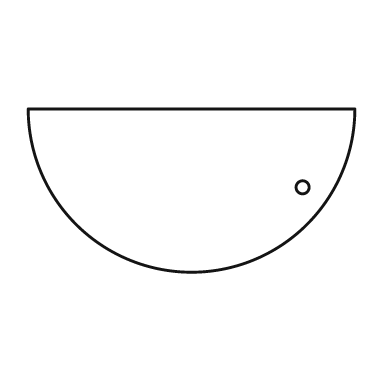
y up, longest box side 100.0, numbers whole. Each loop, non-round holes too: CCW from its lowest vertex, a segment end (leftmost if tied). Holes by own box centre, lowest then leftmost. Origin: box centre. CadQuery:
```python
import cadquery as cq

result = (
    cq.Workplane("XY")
    .moveTo(-50.0, 25.0)
    .threePointArc((0.0, -25.0), (50.0, 25.0))
    .close()
    .moveTo(34.0, 1.0)
    .circle(2.0)
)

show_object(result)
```